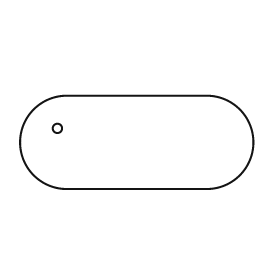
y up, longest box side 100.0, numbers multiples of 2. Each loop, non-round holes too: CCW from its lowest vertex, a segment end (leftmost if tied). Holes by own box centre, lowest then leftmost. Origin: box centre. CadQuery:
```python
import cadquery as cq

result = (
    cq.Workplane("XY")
    .moveTo(-30.0, -20.0)
    .lineTo(30.0, -20.0)
    .threePointArc((50.0, 0.0), (30.0, 20.0))
    .lineTo(-30.0, 20.0)
    .threePointArc((-50.0, 0.0), (-30.0, -20.0))
    .close()
    .moveTo(-34.0, 6.0)
    .circle(2.0)
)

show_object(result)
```